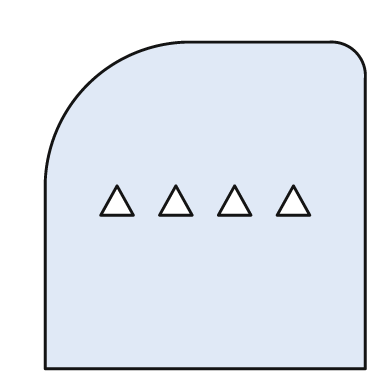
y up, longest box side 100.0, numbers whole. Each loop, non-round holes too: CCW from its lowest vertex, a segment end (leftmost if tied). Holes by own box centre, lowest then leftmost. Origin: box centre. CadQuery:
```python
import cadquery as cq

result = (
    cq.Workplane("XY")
    .moveTo(-49.0, -50.0)
    .lineTo(49.0, -50.0)
    .lineTo(49.0, 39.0)
    .threePointArc((46.0, 47.0), (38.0, 50.0))
    .lineTo(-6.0, 50.0)
    .threePointArc((-36.0, 37.0), (-49.0, 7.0))
    .close()
    .moveTo(-32.0, -3.0)
    .lineTo(-22.0, -3.0)
    .lineTo(-27.0, 6.0)
    .close()
    .moveTo(-14.0, -3.0)
    .lineTo(-4.0, -3.0)
    .lineTo(-9.0, 6.0)
    .close()
    .moveTo(4.0, -3.0)
    .lineTo(14.0, -3.0)
    .lineTo(9.0, 6.0)
    .close()
    .moveTo(22.0, -3.0)
    .lineTo(32.0, -3.0)
    .lineTo(27.0, 6.0)
    .close()
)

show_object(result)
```